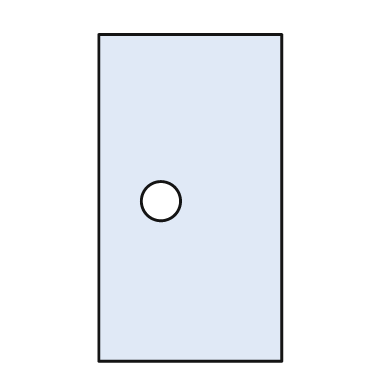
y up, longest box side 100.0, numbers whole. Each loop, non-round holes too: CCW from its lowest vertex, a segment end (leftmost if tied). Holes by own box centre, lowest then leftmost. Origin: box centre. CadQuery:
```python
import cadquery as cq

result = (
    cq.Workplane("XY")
    .moveTo(-28.0, -50.0)
    .lineTo(28.0, -50.0)
    .lineTo(28.0, 50.0)
    .lineTo(-28.0, 50.0)
    .close()
    .moveTo(-9.0, -1.0)
    .circle(6.0)
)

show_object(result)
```